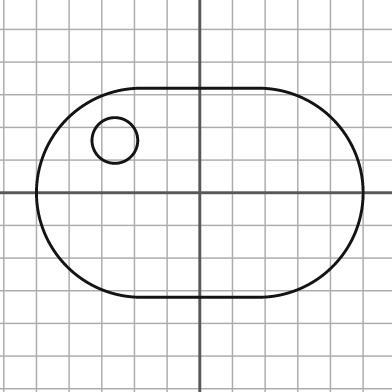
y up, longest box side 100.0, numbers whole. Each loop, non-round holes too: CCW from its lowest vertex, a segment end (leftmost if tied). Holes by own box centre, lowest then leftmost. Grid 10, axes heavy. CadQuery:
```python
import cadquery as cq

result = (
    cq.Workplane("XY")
    .moveTo(-18.0, -32.0)
    .lineTo(18.0, -32.0)
    .threePointArc((50.0, 0.0), (18.0, 32.0))
    .lineTo(-18.0, 32.0)
    .threePointArc((-50.0, 0.0), (-18.0, -32.0))
    .close()
    .moveTo(-26.0, 16.0)
    .circle(7.0)
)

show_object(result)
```